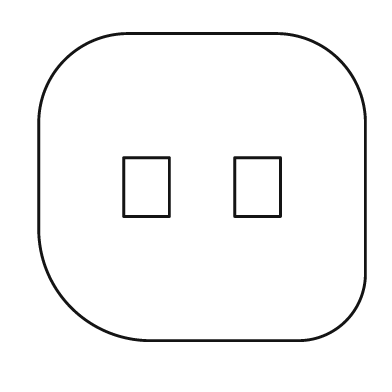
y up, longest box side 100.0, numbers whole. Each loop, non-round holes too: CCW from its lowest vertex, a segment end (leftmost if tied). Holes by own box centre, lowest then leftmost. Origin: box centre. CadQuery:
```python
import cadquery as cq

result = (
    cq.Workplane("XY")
    .moveTo(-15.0, -47.0)
    .lineTo(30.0, -47.0)
    .threePointArc((44.0, -41.0), (50.0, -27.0))
    .lineTo(50.0, 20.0)
    .threePointArc((42.0, 39.0), (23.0, 47.0))
    .lineTo(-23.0, 47.0)
    .threePointArc((-42.0, 39.0), (-50.0, 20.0))
    .lineTo(-50.0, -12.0)
    .threePointArc((-40.0, -37.0), (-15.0, -47.0))
    .close()
    .moveTo(-24.0, -9.0)
    .lineTo(-10.0, -9.0)
    .lineTo(-10.0, 9.0)
    .lineTo(-24.0, 9.0)
    .close()
    .moveTo(10.0, -9.0)
    .lineTo(24.0, -9.0)
    .lineTo(24.0, 9.0)
    .lineTo(10.0, 9.0)
    .close()
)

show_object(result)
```